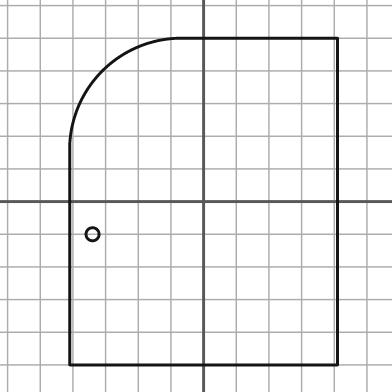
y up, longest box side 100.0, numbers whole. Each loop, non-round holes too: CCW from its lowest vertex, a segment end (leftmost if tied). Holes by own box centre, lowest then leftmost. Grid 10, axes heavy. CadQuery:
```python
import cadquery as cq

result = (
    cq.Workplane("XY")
    .moveTo(-41.0, -50.0)
    .lineTo(41.0, -50.0)
    .lineTo(41.0, 50.0)
    .lineTo(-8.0, 50.0)
    .threePointArc((-31.0, 40.0), (-41.0, 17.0))
    .close()
    .moveTo(-34.0, -10.0)
    .circle(2.0)
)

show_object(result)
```